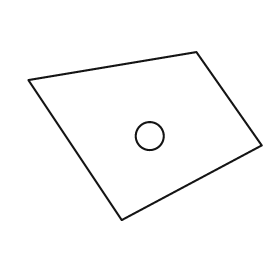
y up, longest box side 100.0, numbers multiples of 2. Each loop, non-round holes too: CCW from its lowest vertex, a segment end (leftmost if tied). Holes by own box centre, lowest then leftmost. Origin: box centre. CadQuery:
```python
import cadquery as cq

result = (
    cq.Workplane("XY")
    .moveTo(-10.0, -36.0)
    .lineTo(50.0, -4.0)
    .lineTo(22.0, 36.0)
    .lineTo(-50.0, 24.0)
    .close()
    .moveTo(2.0, 0.0)
    .circle(6.0)
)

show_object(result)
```